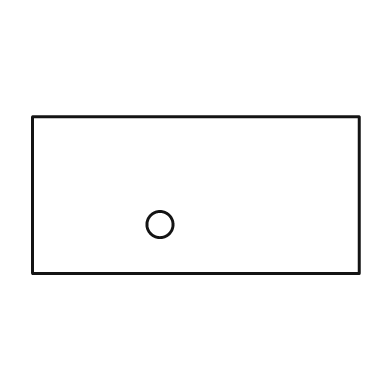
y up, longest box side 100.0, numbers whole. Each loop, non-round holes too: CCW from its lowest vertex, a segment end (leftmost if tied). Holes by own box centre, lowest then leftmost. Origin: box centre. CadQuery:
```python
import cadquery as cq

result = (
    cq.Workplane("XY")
    .moveTo(-50.0, -24.0)
    .lineTo(50.0, -24.0)
    .lineTo(50.0, 24.0)
    .lineTo(-50.0, 24.0)
    .close()
    .moveTo(-11.0, -9.0)
    .circle(4.0)
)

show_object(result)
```